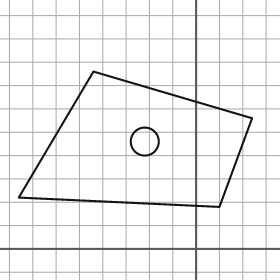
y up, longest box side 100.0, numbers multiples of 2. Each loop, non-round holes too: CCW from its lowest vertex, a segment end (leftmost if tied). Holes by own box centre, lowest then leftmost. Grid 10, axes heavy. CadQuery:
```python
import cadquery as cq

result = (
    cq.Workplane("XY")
    .moveTo(10.0, 18.0)
    .lineTo(24.0, 56.0)
    .lineTo(-44.0, 76.0)
    .lineTo(-76.0, 22.0)
    .close()
    .moveTo(-22.0, 46.0)
    .circle(6.0)
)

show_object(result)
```